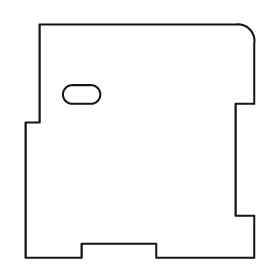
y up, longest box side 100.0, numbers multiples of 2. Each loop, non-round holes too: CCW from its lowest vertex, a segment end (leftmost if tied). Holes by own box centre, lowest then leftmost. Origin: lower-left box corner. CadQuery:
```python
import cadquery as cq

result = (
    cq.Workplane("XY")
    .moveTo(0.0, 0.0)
    .lineTo(24.0, 0.0)
    .lineTo(24.0, 6.0)
    .lineTo(56.0, 6.0)
    .lineTo(56.0, 0.0)
    .lineTo(98.0, 0.0)
    .lineTo(98.0, 18.0)
    .lineTo(90.0, 18.0)
    .lineTo(90.0, 66.0)
    .lineTo(98.0, 66.0)
    .lineTo(98.0, 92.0)
    .threePointArc((96.0, 98.0), (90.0, 100.0))
    .lineTo(6.0, 100.0)
    .lineTo(6.0, 58.0)
    .lineTo(0.0, 58.0)
    .close()
    .moveTo(20.0, 66.0)
    .lineTo(28.0, 66.0)
    .threePointArc((32.0, 70.0), (28.0, 74.0))
    .lineTo(20.0, 74.0)
    .threePointArc((16.0, 70.0), (20.0, 66.0))
    .close()
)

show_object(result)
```